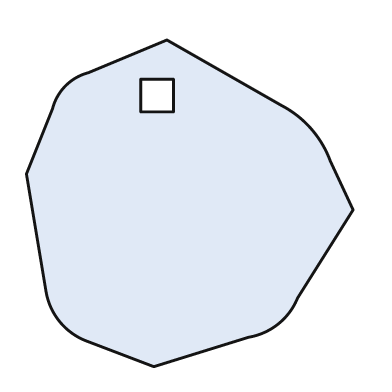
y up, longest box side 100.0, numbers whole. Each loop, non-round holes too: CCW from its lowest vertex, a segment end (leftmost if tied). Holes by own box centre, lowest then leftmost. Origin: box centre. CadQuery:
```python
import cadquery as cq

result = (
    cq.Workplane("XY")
    .moveTo(-11.0, -50.0)
    .lineTo(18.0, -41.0)
    .threePointArc((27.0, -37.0), (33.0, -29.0))
    .lineTo(50.0, -2.0)
    .lineTo(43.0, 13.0)
    .threePointArc((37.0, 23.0), (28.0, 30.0))
    .lineTo(-7.0, 50.0)
    .lineTo(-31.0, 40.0)
    .threePointArc((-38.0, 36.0), (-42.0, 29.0))
    .lineTo(-50.0, 9.0)
    .lineTo(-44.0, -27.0)
    .threePointArc((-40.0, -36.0), (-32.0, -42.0))
    .close()
    .moveTo(-15.0, 28.0)
    .lineTo(-5.0, 28.0)
    .lineTo(-5.0, 38.0)
    .lineTo(-15.0, 38.0)
    .close()
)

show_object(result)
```